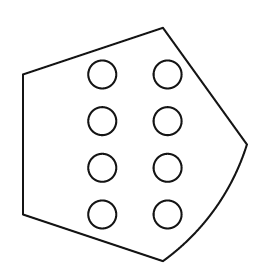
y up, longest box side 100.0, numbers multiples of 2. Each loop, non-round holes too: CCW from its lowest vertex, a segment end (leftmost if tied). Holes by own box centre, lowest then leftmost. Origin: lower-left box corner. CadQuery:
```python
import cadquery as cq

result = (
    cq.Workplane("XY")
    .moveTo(60.0, 0.0)
    .threePointArc((82.0, 22.0), (96.0, 50.0))
    .lineTo(60.0, 100.0)
    .lineTo(0.0, 80.0)
    .lineTo(0.0, 20.0)
    .close()
    .moveTo(34.0, 20.0)
    .circle(6.0)
    .moveTo(62.0, 20.0)
    .circle(6.0)
    .moveTo(34.0, 40.0)
    .circle(6.0)
    .moveTo(62.0, 40.0)
    .circle(6.0)
    .moveTo(34.0, 60.0)
    .circle(6.0)
    .moveTo(62.0, 60.0)
    .circle(6.0)
    .moveTo(34.0, 80.0)
    .circle(6.0)
    .moveTo(62.0, 80.0)
    .circle(6.0)
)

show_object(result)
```